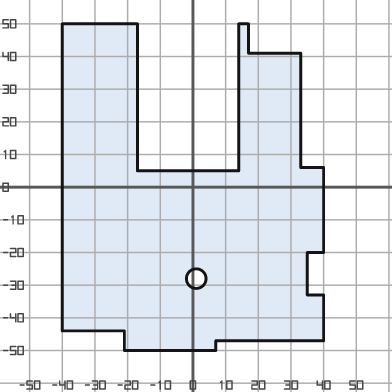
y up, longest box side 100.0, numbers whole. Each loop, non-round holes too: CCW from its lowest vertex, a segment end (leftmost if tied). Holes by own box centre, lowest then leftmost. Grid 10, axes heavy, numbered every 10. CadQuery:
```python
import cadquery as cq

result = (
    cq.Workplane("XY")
    .moveTo(-21.0, -50.0)
    .lineTo(7.0, -50.0)
    .lineTo(7.0, -47.0)
    .lineTo(40.0, -47.0)
    .lineTo(40.0, -33.0)
    .lineTo(35.0, -33.0)
    .lineTo(35.0, -20.0)
    .lineTo(40.0, -20.0)
    .lineTo(40.0, 6.0)
    .lineTo(33.0, 6.0)
    .lineTo(33.0, 41.0)
    .lineTo(17.0, 41.0)
    .lineTo(17.0, 50.0)
    .lineTo(14.0, 50.0)
    .lineTo(14.0, 5.0)
    .lineTo(-17.0, 5.0)
    .lineTo(-17.0, 50.0)
    .lineTo(-40.0, 50.0)
    .lineTo(-40.0, -44.0)
    .lineTo(-21.0, -44.0)
    .close()
    .moveTo(1.0, -28.0)
    .circle(3.0)
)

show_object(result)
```